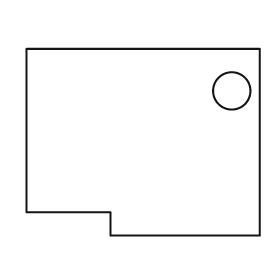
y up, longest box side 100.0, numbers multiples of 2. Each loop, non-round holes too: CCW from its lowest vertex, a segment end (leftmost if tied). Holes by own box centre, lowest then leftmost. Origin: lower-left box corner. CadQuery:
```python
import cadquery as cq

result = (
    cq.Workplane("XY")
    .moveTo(36.0, 0.0)
    .lineTo(100.0, 0.0)
    .lineTo(100.0, 80.0)
    .lineTo(0.0, 80.0)
    .lineTo(0.0, 10.0)
    .lineTo(36.0, 10.0)
    .close()
    .moveTo(88.0, 62.0)
    .circle(8.0)
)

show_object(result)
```